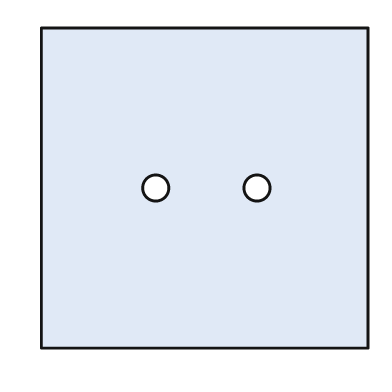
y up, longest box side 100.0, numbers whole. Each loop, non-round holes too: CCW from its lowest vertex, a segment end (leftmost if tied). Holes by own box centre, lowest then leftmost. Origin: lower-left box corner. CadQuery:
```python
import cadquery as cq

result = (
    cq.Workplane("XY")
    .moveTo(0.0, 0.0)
    .lineTo(100.0, 0.0)
    .lineTo(100.0, 98.0)
    .lineTo(0.0, 98.0)
    .close()
    .moveTo(35.0, 49.0)
    .circle(4.0)
    .moveTo(66.0, 49.0)
    .circle(4.0)
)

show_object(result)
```